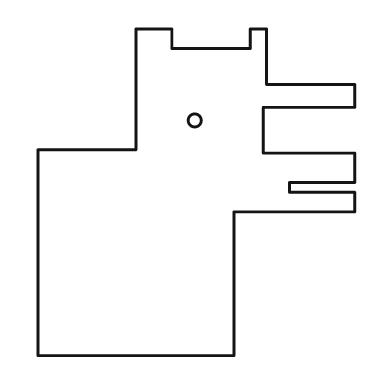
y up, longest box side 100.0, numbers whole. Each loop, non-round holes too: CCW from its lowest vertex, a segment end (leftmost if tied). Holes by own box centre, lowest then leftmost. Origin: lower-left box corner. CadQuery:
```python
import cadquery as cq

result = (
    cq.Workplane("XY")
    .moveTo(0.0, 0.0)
    .lineTo(60.0, 0.0)
    .lineTo(60.0, 44.0)
    .lineTo(97.0, 44.0)
    .lineTo(97.0, 50.0)
    .lineTo(77.0, 50.0)
    .lineTo(77.0, 53.0)
    .lineTo(97.0, 53.0)
    .lineTo(97.0, 62.0)
    .lineTo(69.0, 62.0)
    .lineTo(69.0, 76.0)
    .lineTo(97.0, 76.0)
    .lineTo(97.0, 83.0)
    .lineTo(70.0, 83.0)
    .lineTo(70.0, 100.0)
    .lineTo(65.0, 100.0)
    .lineTo(65.0, 94.0)
    .lineTo(41.0, 94.0)
    .lineTo(41.0, 100.0)
    .lineTo(30.0, 100.0)
    .lineTo(30.0, 63.0)
    .lineTo(0.0, 63.0)
    .close()
    .moveTo(48.0, 72.0)
    .circle(2.0)
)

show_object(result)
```